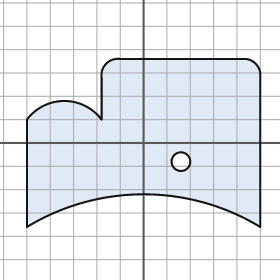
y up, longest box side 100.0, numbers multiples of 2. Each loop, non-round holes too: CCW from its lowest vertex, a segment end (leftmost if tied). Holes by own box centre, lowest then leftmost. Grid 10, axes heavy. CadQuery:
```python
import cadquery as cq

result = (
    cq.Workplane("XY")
    .moveTo(-50.0, -36.0)
    .threePointArc((0.0, -22.0), (50.0, -36.0))
    .lineTo(50.0, 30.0)
    .threePointArc((48.0, 34.0), (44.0, 36.0))
    .lineTo(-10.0, 36.0)
    .threePointArc((-16.0, 34.0), (-18.0, 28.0))
    .lineTo(-18.0, 10.0)
    .threePointArc((-34.0, 18.0), (-50.0, 10.0))
    .close()
    .moveTo(16.0, -8.0)
    .circle(4.0)
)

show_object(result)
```